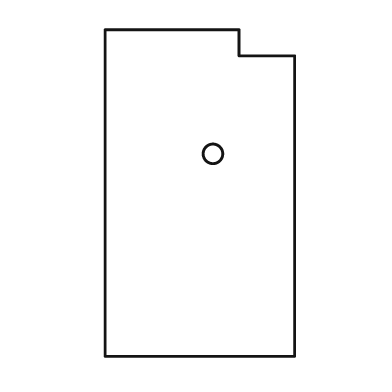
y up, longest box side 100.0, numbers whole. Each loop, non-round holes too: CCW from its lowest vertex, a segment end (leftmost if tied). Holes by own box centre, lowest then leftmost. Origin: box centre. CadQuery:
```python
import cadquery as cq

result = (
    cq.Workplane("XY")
    .moveTo(-29.0, -50.0)
    .lineTo(29.0, -50.0)
    .lineTo(29.0, 42.0)
    .lineTo(12.0, 42.0)
    .lineTo(12.0, 50.0)
    .lineTo(-29.0, 50.0)
    .close()
    .moveTo(4.0, 12.0)
    .circle(3.0)
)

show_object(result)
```